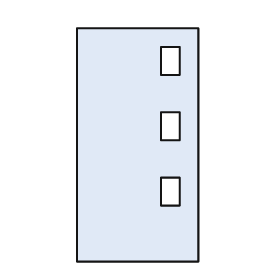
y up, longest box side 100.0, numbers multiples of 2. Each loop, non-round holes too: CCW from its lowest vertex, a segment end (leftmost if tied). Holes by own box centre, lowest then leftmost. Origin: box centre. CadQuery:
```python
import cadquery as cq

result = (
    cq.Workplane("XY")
    .moveTo(-26.0, -50.0)
    .lineTo(26.0, -50.0)
    .lineTo(26.0, 50.0)
    .lineTo(-26.0, 50.0)
    .close()
    .moveTo(10.0, -26.0)
    .lineTo(18.0, -26.0)
    .lineTo(18.0, -14.0)
    .lineTo(10.0, -14.0)
    .close()
    .moveTo(10.0, 2.0)
    .lineTo(18.0, 2.0)
    .lineTo(18.0, 14.0)
    .lineTo(10.0, 14.0)
    .close()
    .moveTo(10.0, 30.0)
    .lineTo(18.0, 30.0)
    .lineTo(18.0, 42.0)
    .lineTo(10.0, 42.0)
    .close()
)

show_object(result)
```